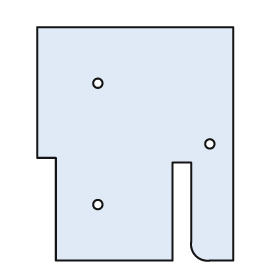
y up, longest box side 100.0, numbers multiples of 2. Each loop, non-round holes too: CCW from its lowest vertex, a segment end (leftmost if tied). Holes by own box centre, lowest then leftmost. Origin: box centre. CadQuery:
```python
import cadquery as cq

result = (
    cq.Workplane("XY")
    .moveTo(-34.0, -50.0)
    .lineTo(16.0, -50.0)
    .lineTo(16.0, -8.0)
    .lineTo(24.0, -8.0)
    .lineTo(24.0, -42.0)
    .threePointArc((26.0, -48.0), (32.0, -50.0))
    .lineTo(42.0, -50.0)
    .lineTo(42.0, 50.0)
    .lineTo(-42.0, 50.0)
    .lineTo(-42.0, -6.0)
    .lineTo(-34.0, -6.0)
    .close()
    .moveTo(-16.0, -26.0)
    .circle(2.0)
    .moveTo(32.0, 0.0)
    .circle(2.0)
    .moveTo(-16.0, 26.0)
    .circle(2.0)
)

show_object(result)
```